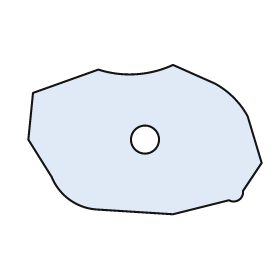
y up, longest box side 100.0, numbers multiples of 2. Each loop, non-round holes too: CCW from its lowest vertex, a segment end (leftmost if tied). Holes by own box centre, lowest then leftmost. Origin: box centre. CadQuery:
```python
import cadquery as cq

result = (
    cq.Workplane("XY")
    .moveTo(12.0, -32.0)
    .lineTo(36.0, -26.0)
    .threePointArc((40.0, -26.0), (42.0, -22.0))
    .lineTo(50.0, -10.0)
    .lineTo(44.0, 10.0)
    .threePointArc((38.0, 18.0), (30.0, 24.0))
    .lineTo(12.0, 32.0)
    .threePointArc((-4.0, 28.0), (-20.0, 30.0))
    .lineTo(-48.0, 20.0)
    .lineTo(-50.0, 0.0)
    .lineTo(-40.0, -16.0)
    .threePointArc((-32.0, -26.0), (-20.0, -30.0))
    .close()
    .moveTo(0.0, 0.0)
    .circle(6.0)
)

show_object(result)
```